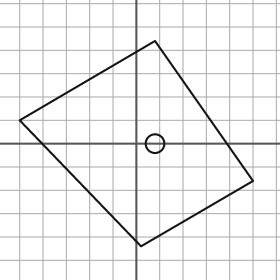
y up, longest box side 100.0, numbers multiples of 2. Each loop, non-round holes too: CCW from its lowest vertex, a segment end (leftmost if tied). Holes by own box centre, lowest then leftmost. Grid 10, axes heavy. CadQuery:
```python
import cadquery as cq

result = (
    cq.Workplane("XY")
    .moveTo(2.0, -44.0)
    .lineTo(50.0, -16.0)
    .lineTo(8.0, 44.0)
    .lineTo(-50.0, 10.0)
    .close()
    .moveTo(8.0, 0.0)
    .circle(4.0)
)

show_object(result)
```